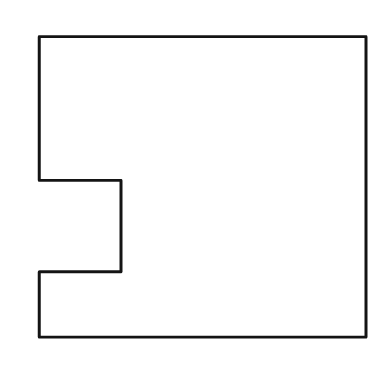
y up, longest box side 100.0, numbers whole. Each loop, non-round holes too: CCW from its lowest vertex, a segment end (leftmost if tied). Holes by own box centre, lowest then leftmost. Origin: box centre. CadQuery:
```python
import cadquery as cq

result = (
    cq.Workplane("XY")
    .moveTo(-50.0, -46.0)
    .lineTo(50.0, -46.0)
    .lineTo(50.0, 46.0)
    .lineTo(-50.0, 46.0)
    .lineTo(-50.0, 2.0)
    .lineTo(-25.0, 2.0)
    .lineTo(-25.0, -26.0)
    .lineTo(-50.0, -26.0)
    .close()
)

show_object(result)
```